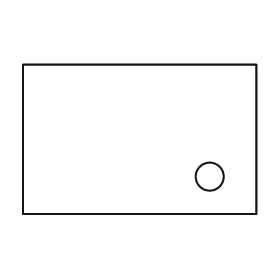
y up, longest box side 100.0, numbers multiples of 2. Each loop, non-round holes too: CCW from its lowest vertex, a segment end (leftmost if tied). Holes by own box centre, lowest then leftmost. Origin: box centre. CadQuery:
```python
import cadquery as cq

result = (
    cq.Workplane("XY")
    .moveTo(-50.0, -32.0)
    .lineTo(50.0, -32.0)
    .lineTo(50.0, 32.0)
    .lineTo(-50.0, 32.0)
    .close()
    .moveTo(30.0, -16.0)
    .circle(6.0)
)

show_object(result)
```